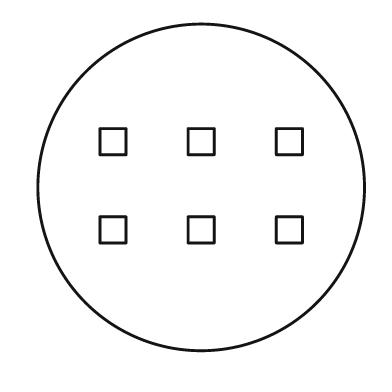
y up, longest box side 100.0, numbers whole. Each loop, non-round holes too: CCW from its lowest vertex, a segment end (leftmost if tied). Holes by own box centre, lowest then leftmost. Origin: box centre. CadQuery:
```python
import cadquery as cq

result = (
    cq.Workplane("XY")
    .moveTo(0.0, 0.0)
    .circle(50.0)
    .moveTo(-31.0, -17.0)
    .lineTo(-23.0, -17.0)
    .lineTo(-23.0, -9.0)
    .lineTo(-31.0, -9.0)
    .close()
    .moveTo(-4.0, -17.0)
    .lineTo(4.0, -17.0)
    .lineTo(4.0, -9.0)
    .lineTo(-4.0, -9.0)
    .close()
    .moveTo(23.0, -17.0)
    .lineTo(31.0, -17.0)
    .lineTo(31.0, -9.0)
    .lineTo(23.0, -9.0)
    .close()
    .moveTo(-31.0, 10.0)
    .lineTo(-23.0, 10.0)
    .lineTo(-23.0, 18.0)
    .lineTo(-31.0, 18.0)
    .close()
    .moveTo(-4.0, 10.0)
    .lineTo(4.0, 10.0)
    .lineTo(4.0, 18.0)
    .lineTo(-4.0, 18.0)
    .close()
    .moveTo(23.0, 10.0)
    .lineTo(31.0, 10.0)
    .lineTo(31.0, 18.0)
    .lineTo(23.0, 18.0)
    .close()
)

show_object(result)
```